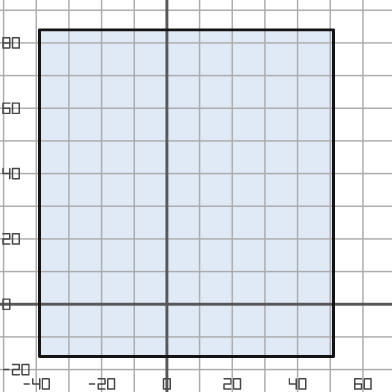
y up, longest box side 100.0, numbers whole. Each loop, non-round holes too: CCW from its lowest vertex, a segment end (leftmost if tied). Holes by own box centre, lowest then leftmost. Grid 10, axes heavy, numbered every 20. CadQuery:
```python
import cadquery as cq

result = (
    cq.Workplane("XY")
    .moveTo(-39.0, -16.0)
    .lineTo(51.0, -16.0)
    .lineTo(51.0, 84.0)
    .lineTo(-39.0, 84.0)
    .close()
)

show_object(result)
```